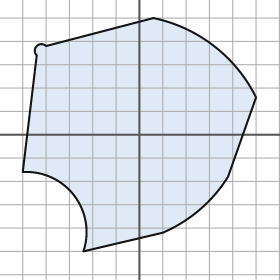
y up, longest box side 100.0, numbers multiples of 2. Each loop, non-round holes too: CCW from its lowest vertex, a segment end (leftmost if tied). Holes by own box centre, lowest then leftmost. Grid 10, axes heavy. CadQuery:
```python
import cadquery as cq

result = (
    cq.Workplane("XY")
    .moveTo(-24.0, -50.0)
    .lineTo(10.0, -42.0)
    .threePointArc((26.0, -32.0), (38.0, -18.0))
    .lineTo(50.0, 16.0)
    .threePointArc((32.0, 38.0), (6.0, 50.0))
    .lineTo(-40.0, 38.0)
    .threePointArc((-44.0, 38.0), (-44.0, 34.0))
    .lineTo(-50.0, -16.0)
    .threePointArc((-28.0, -26.0), (-24.0, -50.0))
    .close()
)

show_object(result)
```